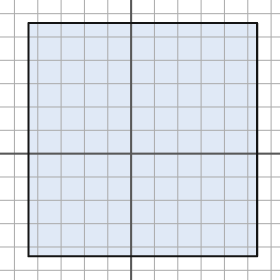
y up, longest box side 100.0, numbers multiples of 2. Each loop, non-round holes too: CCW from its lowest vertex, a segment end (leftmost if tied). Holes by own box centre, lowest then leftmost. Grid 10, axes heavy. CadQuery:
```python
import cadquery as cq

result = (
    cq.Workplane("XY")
    .moveTo(-44.0, -44.0)
    .lineTo(54.0, -44.0)
    .lineTo(54.0, 56.0)
    .lineTo(-44.0, 56.0)
    .close()
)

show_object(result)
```